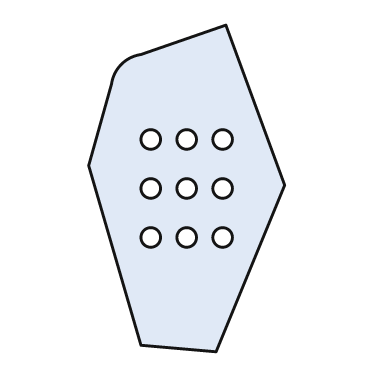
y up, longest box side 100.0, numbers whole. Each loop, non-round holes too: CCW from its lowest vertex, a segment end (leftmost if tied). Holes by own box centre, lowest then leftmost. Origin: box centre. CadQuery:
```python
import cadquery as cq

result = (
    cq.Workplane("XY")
    .moveTo(9.0, -50.0)
    .lineTo(30.0, 1.0)
    .lineTo(12.0, 50.0)
    .lineTo(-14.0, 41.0)
    .threePointArc((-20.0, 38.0), (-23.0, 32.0))
    .lineTo(-30.0, 7.0)
    .lineTo(-14.0, -48.0)
    .close()
    .moveTo(-11.0, -15.0)
    .circle(3.0)
    .moveTo(0.0, -15.0)
    .circle(3.0)
    .moveTo(11.0, -15.0)
    .circle(3.0)
    .moveTo(-11.0, 0.0)
    .circle(3.0)
    .moveTo(0.0, 0.0)
    .circle(3.0)
    .moveTo(11.0, 0.0)
    .circle(3.0)
    .moveTo(-11.0, 15.0)
    .circle(3.0)
    .moveTo(0.0, 15.0)
    .circle(3.0)
    .moveTo(11.0, 15.0)
    .circle(3.0)
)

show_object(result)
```